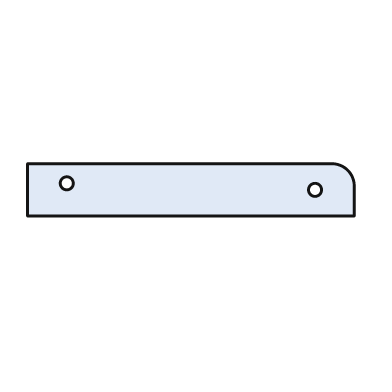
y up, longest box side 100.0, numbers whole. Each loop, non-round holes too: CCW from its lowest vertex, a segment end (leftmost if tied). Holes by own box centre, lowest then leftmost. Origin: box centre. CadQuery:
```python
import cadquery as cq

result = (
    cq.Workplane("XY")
    .moveTo(-50.0, -8.0)
    .lineTo(50.0, -8.0)
    .lineTo(50.0, 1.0)
    .threePointArc((48.0, 6.0), (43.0, 8.0))
    .lineTo(-50.0, 8.0)
    .close()
    .moveTo(38.0, 0.0)
    .circle(2.0)
    .moveTo(-38.0, 2.0)
    .circle(2.0)
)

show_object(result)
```